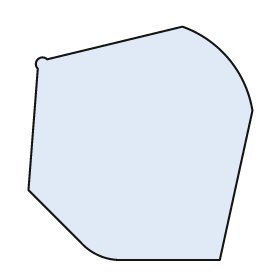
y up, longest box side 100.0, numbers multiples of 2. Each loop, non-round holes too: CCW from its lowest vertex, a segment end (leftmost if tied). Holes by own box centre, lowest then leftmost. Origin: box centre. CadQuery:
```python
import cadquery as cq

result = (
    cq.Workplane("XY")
    .moveTo(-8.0, -50.0)
    .lineTo(34.0, -50.0)
    .lineTo(48.0, 14.0)
    .threePointArc((38.0, 36.0), (18.0, 50.0))
    .lineTo(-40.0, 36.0)
    .threePointArc((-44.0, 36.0), (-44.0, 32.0))
    .lineTo(-48.0, -20.0)
    .lineTo(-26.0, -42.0)
    .threePointArc((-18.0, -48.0), (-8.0, -50.0))
    .close()
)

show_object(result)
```